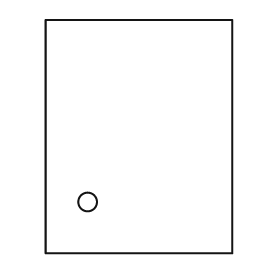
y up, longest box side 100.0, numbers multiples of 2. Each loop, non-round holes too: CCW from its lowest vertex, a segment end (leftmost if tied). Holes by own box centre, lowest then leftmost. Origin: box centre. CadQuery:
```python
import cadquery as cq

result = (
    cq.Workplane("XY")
    .moveTo(-40.0, -50.0)
    .lineTo(40.0, -50.0)
    .lineTo(40.0, 50.0)
    .lineTo(-40.0, 50.0)
    .close()
    .moveTo(-22.0, -28.0)
    .circle(4.0)
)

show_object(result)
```